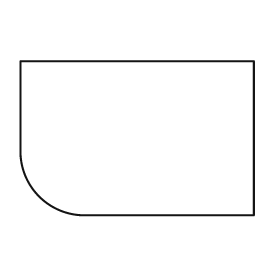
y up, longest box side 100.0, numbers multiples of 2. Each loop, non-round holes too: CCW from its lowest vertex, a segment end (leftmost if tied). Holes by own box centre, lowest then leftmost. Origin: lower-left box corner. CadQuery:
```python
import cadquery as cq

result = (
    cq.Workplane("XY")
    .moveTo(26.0, 0.0)
    .lineTo(100.0, 0.0)
    .lineTo(100.0, 66.0)
    .lineTo(0.0, 66.0)
    .lineTo(0.0, 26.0)
    .threePointArc((8.0, 8.0), (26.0, 0.0))
    .close()
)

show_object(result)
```